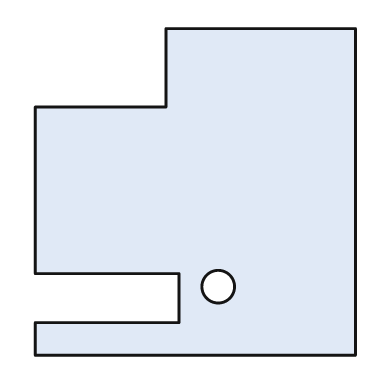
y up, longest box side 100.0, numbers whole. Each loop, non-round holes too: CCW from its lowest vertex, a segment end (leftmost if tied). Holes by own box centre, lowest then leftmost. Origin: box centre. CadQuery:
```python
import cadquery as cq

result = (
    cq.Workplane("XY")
    .moveTo(-49.0, -50.0)
    .lineTo(49.0, -50.0)
    .lineTo(49.0, 50.0)
    .lineTo(-9.0, 50.0)
    .lineTo(-9.0, 26.0)
    .lineTo(-49.0, 26.0)
    .lineTo(-49.0, -25.0)
    .lineTo(-5.0, -25.0)
    .lineTo(-5.0, -40.0)
    .lineTo(-49.0, -40.0)
    .close()
    .moveTo(7.0, -29.0)
    .circle(5.0)
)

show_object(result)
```